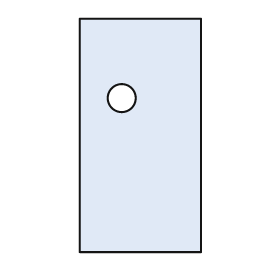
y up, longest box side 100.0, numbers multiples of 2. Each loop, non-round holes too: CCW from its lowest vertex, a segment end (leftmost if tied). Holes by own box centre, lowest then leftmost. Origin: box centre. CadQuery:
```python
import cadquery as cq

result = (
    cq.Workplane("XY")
    .moveTo(-26.0, -50.0)
    .lineTo(26.0, -50.0)
    .lineTo(26.0, 50.0)
    .lineTo(-26.0, 50.0)
    .close()
    .moveTo(-8.0, 16.0)
    .circle(6.0)
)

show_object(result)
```